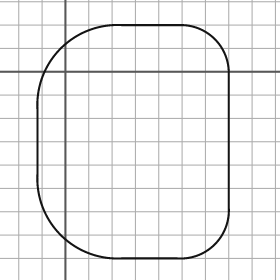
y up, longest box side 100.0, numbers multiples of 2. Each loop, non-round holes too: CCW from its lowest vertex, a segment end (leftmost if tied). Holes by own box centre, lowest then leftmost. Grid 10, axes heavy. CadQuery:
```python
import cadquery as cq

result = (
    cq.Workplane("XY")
    .moveTo(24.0, -80.0)
    .lineTo(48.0, -80.0)
    .threePointArc((64.0, -74.0), (70.0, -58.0))
    .lineTo(70.0, 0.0)
    .threePointArc((64.0, 14.0), (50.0, 20.0))
    .lineTo(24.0, 20.0)
    .threePointArc((-2.0, 10.0), (-12.0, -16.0))
    .lineTo(-12.0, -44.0)
    .threePointArc((-2.0, -70.0), (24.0, -80.0))
    .close()
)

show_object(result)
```